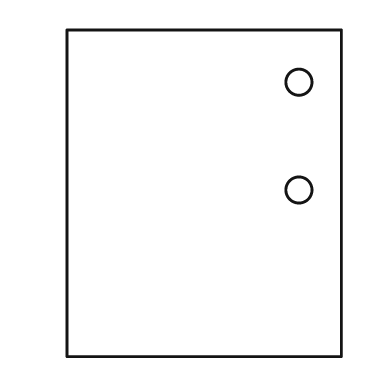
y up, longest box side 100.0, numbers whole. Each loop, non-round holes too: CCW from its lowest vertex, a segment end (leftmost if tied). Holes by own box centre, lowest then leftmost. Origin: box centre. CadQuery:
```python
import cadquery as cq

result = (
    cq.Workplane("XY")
    .moveTo(-42.0, -50.0)
    .lineTo(42.0, -50.0)
    .lineTo(42.0, 50.0)
    .lineTo(-42.0, 50.0)
    .close()
    .moveTo(29.0, 1.0)
    .circle(4.0)
    .moveTo(29.0, 34.0)
    .circle(4.0)
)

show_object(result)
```